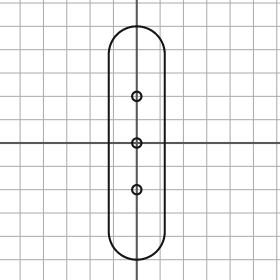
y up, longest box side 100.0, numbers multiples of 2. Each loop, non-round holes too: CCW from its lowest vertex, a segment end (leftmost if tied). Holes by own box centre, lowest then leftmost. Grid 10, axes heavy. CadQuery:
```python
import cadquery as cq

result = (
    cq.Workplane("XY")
    .moveTo(-12.0, -38.0)
    .threePointArc((0.0, -50.0), (12.0, -38.0))
    .lineTo(12.0, 38.0)
    .threePointArc((0.0, 50.0), (-12.0, 38.0))
    .close()
    .moveTo(0.0, -20.0)
    .circle(2.0)
    .moveTo(0.0, 0.0)
    .circle(2.0)
    .moveTo(0.0, 20.0)
    .circle(2.0)
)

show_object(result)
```